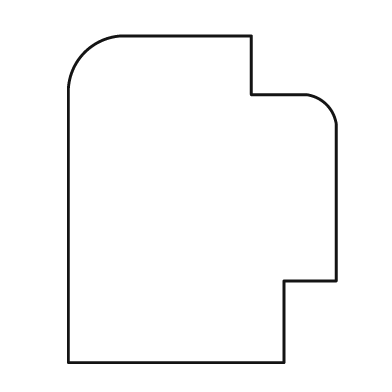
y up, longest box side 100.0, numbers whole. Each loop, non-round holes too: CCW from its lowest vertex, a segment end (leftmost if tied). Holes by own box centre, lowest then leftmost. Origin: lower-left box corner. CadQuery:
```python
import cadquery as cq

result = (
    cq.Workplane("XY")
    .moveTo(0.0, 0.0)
    .lineTo(66.0, 0.0)
    .lineTo(66.0, 25.0)
    .lineTo(82.0, 25.0)
    .lineTo(82.0, 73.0)
    .threePointArc((79.0, 79.0), (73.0, 82.0))
    .lineTo(56.0, 82.0)
    .lineTo(56.0, 100.0)
    .lineTo(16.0, 100.0)
    .threePointArc((5.0, 95.0), (0.0, 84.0))
    .close()
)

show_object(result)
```